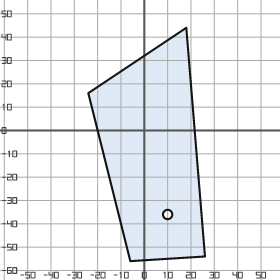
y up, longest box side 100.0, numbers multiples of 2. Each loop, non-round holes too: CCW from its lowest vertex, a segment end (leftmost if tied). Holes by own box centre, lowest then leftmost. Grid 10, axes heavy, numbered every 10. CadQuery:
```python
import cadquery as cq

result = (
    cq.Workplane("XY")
    .moveTo(-6.0, -56.0)
    .lineTo(26.0, -54.0)
    .lineTo(18.0, 44.0)
    .lineTo(-24.0, 16.0)
    .close()
    .moveTo(10.0, -36.0)
    .circle(2.0)
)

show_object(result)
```